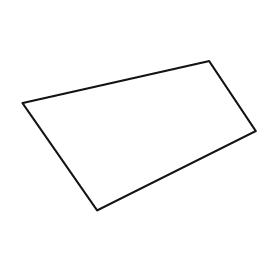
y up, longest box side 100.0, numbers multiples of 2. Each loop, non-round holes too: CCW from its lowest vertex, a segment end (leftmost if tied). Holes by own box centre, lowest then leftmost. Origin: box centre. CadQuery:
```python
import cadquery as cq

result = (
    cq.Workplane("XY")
    .moveTo(-18.0, -32.0)
    .lineTo(50.0, 2.0)
    .lineTo(30.0, 32.0)
    .lineTo(-50.0, 14.0)
    .close()
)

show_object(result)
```